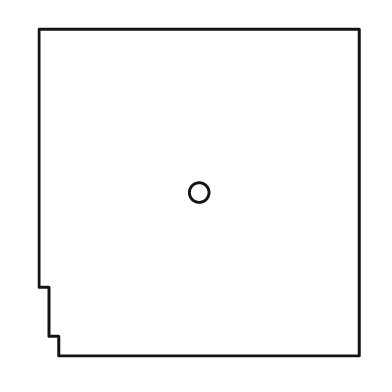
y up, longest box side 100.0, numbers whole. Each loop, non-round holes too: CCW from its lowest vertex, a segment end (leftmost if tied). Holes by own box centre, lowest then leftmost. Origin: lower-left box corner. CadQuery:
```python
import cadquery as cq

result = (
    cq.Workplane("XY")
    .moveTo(6.0, 0.0)
    .lineTo(98.0, 0.0)
    .lineTo(98.0, 100.0)
    .lineTo(0.0, 100.0)
    .lineTo(0.0, 21.0)
    .lineTo(3.0, 21.0)
    .lineTo(3.0, 6.0)
    .lineTo(6.0, 6.0)
    .close()
    .moveTo(49.0, 50.0)
    .circle(3.0)
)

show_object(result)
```